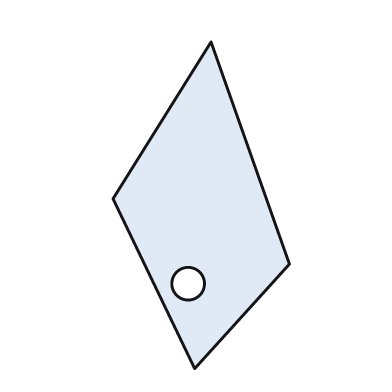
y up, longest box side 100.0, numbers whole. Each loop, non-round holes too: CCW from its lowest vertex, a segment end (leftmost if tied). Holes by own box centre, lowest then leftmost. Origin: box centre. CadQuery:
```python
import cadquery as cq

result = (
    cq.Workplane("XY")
    .moveTo(-2.0, -50.0)
    .lineTo(27.0, -18.0)
    .lineTo(3.0, 50.0)
    .lineTo(-27.0, 2.0)
    .close()
    .moveTo(-4.0, -24.0)
    .circle(5.0)
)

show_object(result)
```